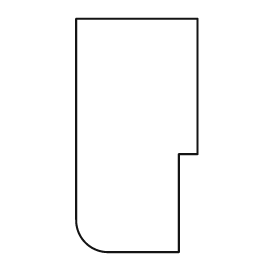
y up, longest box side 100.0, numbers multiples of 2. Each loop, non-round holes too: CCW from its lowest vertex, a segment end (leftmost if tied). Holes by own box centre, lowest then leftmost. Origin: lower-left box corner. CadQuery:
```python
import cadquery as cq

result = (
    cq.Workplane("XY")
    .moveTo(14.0, 0.0)
    .lineTo(44.0, 0.0)
    .lineTo(44.0, 42.0)
    .lineTo(52.0, 42.0)
    .lineTo(52.0, 100.0)
    .lineTo(0.0, 100.0)
    .lineTo(0.0, 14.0)
    .threePointArc((4.0, 4.0), (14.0, 0.0))
    .close()
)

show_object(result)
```